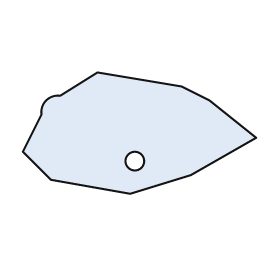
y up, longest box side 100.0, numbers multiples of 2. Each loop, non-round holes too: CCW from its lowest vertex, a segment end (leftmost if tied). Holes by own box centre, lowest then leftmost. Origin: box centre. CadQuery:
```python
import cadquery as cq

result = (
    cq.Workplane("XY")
    .moveTo(-4.0, -26.0)
    .lineTo(22.0, -18.0)
    .lineTo(50.0, -2.0)
    .lineTo(30.0, 14.0)
    .lineTo(18.0, 20.0)
    .lineTo(-18.0, 26.0)
    .lineTo(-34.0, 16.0)
    .threePointArc((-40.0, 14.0), (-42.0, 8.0))
    .lineTo(-50.0, -8.0)
    .lineTo(-38.0, -20.0)
    .close()
    .moveTo(-2.0, -12.0)
    .circle(4.0)
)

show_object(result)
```